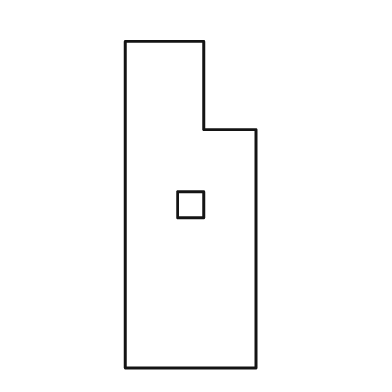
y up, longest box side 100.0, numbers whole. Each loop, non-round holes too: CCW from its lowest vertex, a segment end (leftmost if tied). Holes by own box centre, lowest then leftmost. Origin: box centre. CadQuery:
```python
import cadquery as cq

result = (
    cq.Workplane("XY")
    .moveTo(-20.0, -50.0)
    .lineTo(20.0, -50.0)
    .lineTo(20.0, 23.0)
    .lineTo(4.0, 23.0)
    .lineTo(4.0, 50.0)
    .lineTo(-20.0, 50.0)
    .close()
    .moveTo(-4.0, -4.0)
    .lineTo(4.0, -4.0)
    .lineTo(4.0, 4.0)
    .lineTo(-4.0, 4.0)
    .close()
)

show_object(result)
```